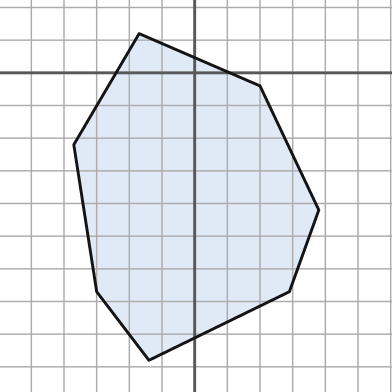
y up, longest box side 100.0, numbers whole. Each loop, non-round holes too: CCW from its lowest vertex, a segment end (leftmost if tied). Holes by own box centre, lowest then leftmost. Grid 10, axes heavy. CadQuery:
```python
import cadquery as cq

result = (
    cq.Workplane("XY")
    .moveTo(-14.0, -88.0)
    .lineTo(29.0, -67.0)
    .lineTo(38.0, -42.0)
    .lineTo(20.0, -4.0)
    .lineTo(-17.0, 12.0)
    .lineTo(-37.0, -22.0)
    .lineTo(-30.0, -67.0)
    .close()
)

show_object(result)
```